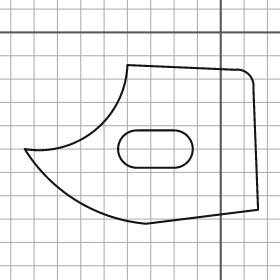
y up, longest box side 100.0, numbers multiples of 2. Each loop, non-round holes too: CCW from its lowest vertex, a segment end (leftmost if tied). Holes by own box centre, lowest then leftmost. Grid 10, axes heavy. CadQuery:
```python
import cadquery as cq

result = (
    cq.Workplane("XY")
    .moveTo(-32.0, -82.0)
    .lineTo(16.0, -76.0)
    .lineTo(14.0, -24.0)
    .threePointArc((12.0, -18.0), (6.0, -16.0))
    .lineTo(-40.0, -14.0)
    .threePointArc((-54.0, -42.0), (-84.0, -50.0))
    .threePointArc((-62.0, -72.0), (-32.0, -82.0))
    .close()
    .moveTo(-36.0, -58.0)
    .lineTo(-20.0, -58.0)
    .threePointArc((-12.0, -50.0), (-20.0, -42.0))
    .lineTo(-36.0, -42.0)
    .threePointArc((-44.0, -50.0), (-36.0, -58.0))
    .close()
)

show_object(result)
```